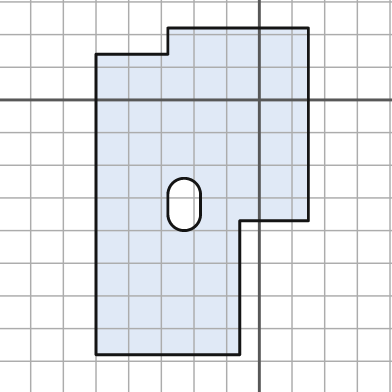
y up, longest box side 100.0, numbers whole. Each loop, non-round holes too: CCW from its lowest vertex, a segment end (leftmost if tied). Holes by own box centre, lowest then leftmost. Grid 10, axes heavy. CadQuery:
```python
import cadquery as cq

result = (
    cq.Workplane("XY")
    .moveTo(-50.0, -78.0)
    .lineTo(-6.0, -78.0)
    .lineTo(-6.0, -37.0)
    .lineTo(15.0, -37.0)
    .lineTo(15.0, 22.0)
    .lineTo(-28.0, 22.0)
    .lineTo(-28.0, 14.0)
    .lineTo(-50.0, 14.0)
    .close()
    .moveTo(-28.0, -35.0)
    .threePointArc((-23.0, -40.0), (-18.0, -35.0))
    .lineTo(-18.0, -29.0)
    .threePointArc((-23.0, -24.0), (-28.0, -29.0))
    .close()
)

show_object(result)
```